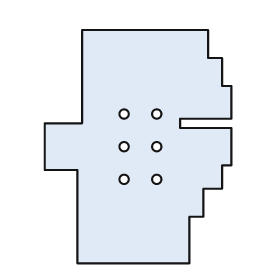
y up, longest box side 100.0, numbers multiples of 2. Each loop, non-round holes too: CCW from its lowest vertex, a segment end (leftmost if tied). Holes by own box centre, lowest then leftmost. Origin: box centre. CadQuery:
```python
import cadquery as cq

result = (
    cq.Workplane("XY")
    .moveTo(-26.0, -50.0)
    .lineTo(22.0, -50.0)
    .lineTo(22.0, -30.0)
    .lineTo(28.0, -30.0)
    .lineTo(28.0, -18.0)
    .lineTo(36.0, -18.0)
    .lineTo(36.0, -8.0)
    .lineTo(40.0, -8.0)
    .lineTo(40.0, 8.0)
    .lineTo(18.0, 8.0)
    .lineTo(18.0, 12.0)
    .lineTo(40.0, 12.0)
    .lineTo(40.0, 26.0)
    .lineTo(36.0, 26.0)
    .lineTo(36.0, 38.0)
    .lineTo(30.0, 38.0)
    .lineTo(30.0, 50.0)
    .lineTo(-24.0, 50.0)
    .lineTo(-24.0, 10.0)
    .lineTo(-40.0, 10.0)
    .lineTo(-40.0, -10.0)
    .lineTo(-26.0, -10.0)
    .close()
    .moveTo(-6.0, -14.0)
    .circle(2.0)
    .moveTo(8.0, -14.0)
    .circle(2.0)
    .moveTo(-6.0, 0.0)
    .circle(2.0)
    .moveTo(8.0, 0.0)
    .circle(2.0)
    .moveTo(-6.0, 14.0)
    .circle(2.0)
    .moveTo(8.0, 14.0)
    .circle(2.0)
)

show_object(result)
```